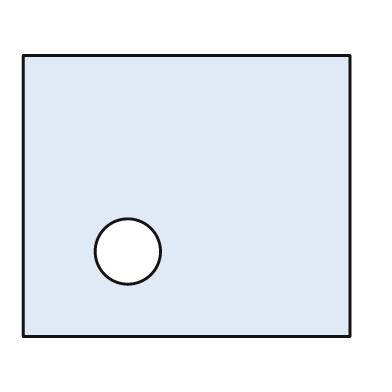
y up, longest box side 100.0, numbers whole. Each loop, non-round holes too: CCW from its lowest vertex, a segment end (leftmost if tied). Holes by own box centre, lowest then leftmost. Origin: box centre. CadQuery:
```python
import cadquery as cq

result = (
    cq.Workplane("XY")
    .moveTo(-50.0, -43.0)
    .lineTo(50.0, -43.0)
    .lineTo(50.0, 43.0)
    .lineTo(-50.0, 43.0)
    .close()
    .moveTo(-18.0, -17.0)
    .circle(10.0)
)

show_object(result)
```